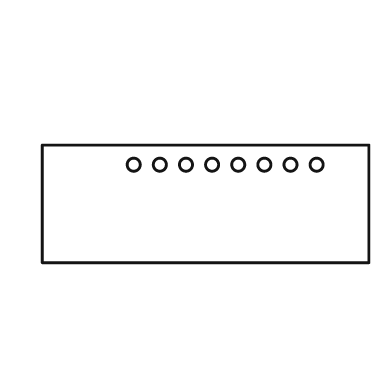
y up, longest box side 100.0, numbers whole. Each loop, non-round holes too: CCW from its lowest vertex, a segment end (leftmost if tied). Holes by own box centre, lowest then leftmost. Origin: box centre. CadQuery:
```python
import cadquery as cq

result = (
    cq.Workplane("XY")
    .moveTo(-50.0, -18.0)
    .lineTo(50.0, -18.0)
    .lineTo(50.0, 18.0)
    .lineTo(-50.0, 18.0)
    .close()
    .moveTo(-22.0, 12.0)
    .circle(2.0)
    .moveTo(-14.0, 12.0)
    .circle(2.0)
    .moveTo(-6.0, 12.0)
    .circle(2.0)
    .moveTo(2.0, 12.0)
    .circle(2.0)
    .moveTo(10.0, 12.0)
    .circle(2.0)
    .moveTo(18.0, 12.0)
    .circle(2.0)
    .moveTo(26.0, 12.0)
    .circle(2.0)
    .moveTo(34.0, 12.0)
    .circle(2.0)
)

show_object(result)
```